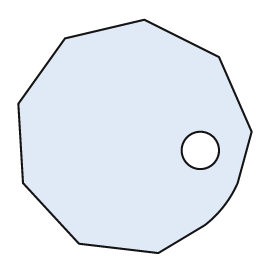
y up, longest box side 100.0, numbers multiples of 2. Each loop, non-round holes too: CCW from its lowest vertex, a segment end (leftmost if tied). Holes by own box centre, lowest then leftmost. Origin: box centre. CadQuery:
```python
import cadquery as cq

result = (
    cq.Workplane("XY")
    .moveTo(10.0, -50.0)
    .lineTo(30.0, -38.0)
    .threePointArc((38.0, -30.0), (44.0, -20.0))
    .lineTo(50.0, 2.0)
    .lineTo(36.0, 34.0)
    .lineTo(4.0, 50.0)
    .lineTo(-30.0, 42.0)
    .lineTo(-50.0, 14.0)
    .lineTo(-48.0, -20.0)
    .lineTo(-24.0, -46.0)
    .close()
    .moveTo(28.0, -6.0)
    .circle(8.0)
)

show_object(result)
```